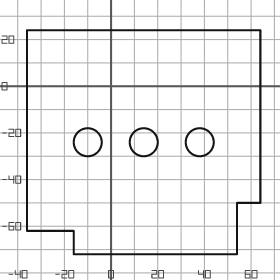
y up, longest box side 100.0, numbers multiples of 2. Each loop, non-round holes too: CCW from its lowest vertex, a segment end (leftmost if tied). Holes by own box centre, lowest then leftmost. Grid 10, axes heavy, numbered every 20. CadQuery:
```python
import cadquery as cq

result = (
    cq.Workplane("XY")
    .moveTo(-16.0, -72.0)
    .lineTo(54.0, -72.0)
    .lineTo(54.0, -50.0)
    .lineTo(64.0, -50.0)
    .lineTo(64.0, 24.0)
    .lineTo(-36.0, 24.0)
    .lineTo(-36.0, -62.0)
    .lineTo(-16.0, -62.0)
    .close()
    .moveTo(-10.0, -24.0)
    .circle(6.0)
    .moveTo(14.0, -24.0)
    .circle(6.0)
    .moveTo(38.0, -24.0)
    .circle(6.0)
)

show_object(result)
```